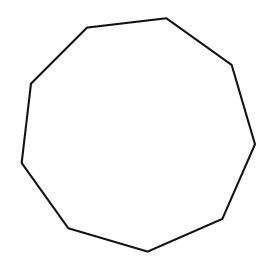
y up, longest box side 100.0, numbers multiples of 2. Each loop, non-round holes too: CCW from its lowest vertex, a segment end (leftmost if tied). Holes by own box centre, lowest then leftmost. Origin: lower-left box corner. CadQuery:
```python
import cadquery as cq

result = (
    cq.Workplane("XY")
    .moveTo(54.0, 0.0)
    .lineTo(86.0, 14.0)
    .lineTo(100.0, 46.0)
    .lineTo(90.0, 80.0)
    .lineTo(62.0, 100.0)
    .lineTo(28.0, 96.0)
    .lineTo(4.0, 72.0)
    .lineTo(0.0, 38.0)
    .lineTo(20.0, 10.0)
    .close()
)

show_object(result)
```